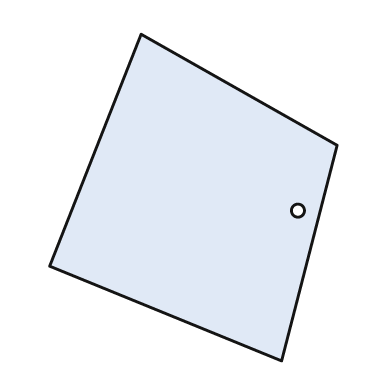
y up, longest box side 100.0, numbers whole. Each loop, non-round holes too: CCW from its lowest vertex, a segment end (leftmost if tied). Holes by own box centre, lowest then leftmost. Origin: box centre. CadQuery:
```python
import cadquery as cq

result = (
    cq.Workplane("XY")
    .moveTo(27.0, -50.0)
    .lineTo(44.0, 16.0)
    .lineTo(-16.0, 50.0)
    .lineTo(-44.0, -21.0)
    .close()
    .moveTo(32.0, -4.0)
    .circle(2.0)
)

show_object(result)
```